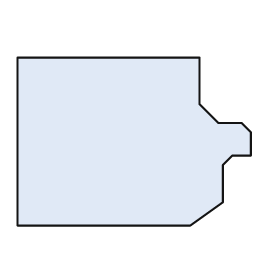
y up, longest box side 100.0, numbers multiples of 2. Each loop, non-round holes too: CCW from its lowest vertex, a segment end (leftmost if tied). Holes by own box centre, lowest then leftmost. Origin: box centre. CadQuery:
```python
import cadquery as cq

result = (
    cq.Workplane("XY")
    .moveTo(-50.0, -36.0)
    .lineTo(24.0, -36.0)
    .lineTo(38.0, -26.0)
    .lineTo(38.0, -10.0)
    .lineTo(42.0, -6.0)
    .lineTo(50.0, -6.0)
    .lineTo(50.0, 4.0)
    .lineTo(46.0, 8.0)
    .lineTo(36.0, 8.0)
    .lineTo(28.0, 16.0)
    .lineTo(28.0, 36.0)
    .lineTo(-50.0, 36.0)
    .close()
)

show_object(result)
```